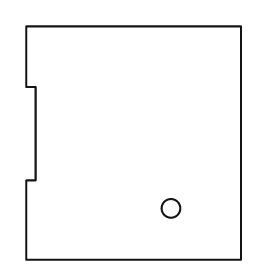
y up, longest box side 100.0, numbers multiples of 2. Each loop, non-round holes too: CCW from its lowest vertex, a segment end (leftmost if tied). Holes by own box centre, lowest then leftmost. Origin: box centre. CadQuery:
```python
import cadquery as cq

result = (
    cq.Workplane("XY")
    .moveTo(-46.0, -50.0)
    .lineTo(46.0, -50.0)
    .lineTo(46.0, 50.0)
    .lineTo(-46.0, 50.0)
    .lineTo(-46.0, 24.0)
    .lineTo(-42.0, 24.0)
    .lineTo(-42.0, -16.0)
    .lineTo(-46.0, -16.0)
    .close()
    .moveTo(16.0, -28.0)
    .circle(4.0)
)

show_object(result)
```